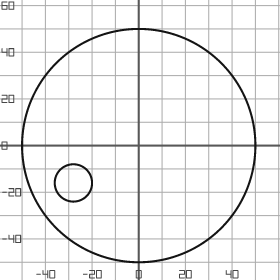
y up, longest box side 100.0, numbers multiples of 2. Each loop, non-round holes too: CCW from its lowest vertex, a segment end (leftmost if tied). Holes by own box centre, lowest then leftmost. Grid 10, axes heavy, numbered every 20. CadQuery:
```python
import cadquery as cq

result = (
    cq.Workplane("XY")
    .moveTo(0.0, 0.0)
    .circle(50.0)
    .moveTo(-28.0, -16.0)
    .circle(8.0)
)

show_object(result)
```